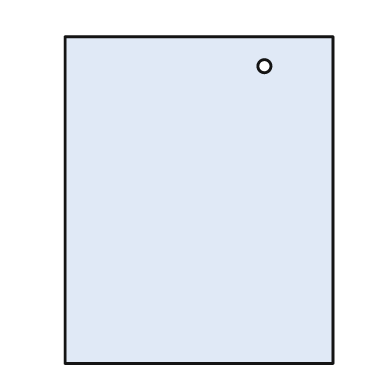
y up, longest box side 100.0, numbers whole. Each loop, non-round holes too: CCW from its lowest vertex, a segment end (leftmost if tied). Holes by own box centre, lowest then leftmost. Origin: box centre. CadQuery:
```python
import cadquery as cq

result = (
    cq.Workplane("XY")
    .moveTo(-41.0, -50.0)
    .lineTo(41.0, -50.0)
    .lineTo(41.0, 50.0)
    .lineTo(-41.0, 50.0)
    .close()
    .moveTo(20.0, 41.0)
    .circle(2.0)
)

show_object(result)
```